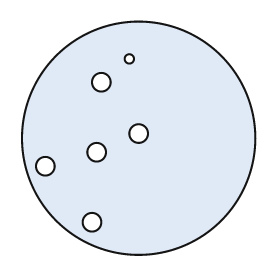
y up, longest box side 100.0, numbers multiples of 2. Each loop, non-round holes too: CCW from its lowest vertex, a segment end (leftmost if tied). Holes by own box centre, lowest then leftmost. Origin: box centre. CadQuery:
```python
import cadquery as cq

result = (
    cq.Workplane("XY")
    .moveTo(0.0, 0.0)
    .circle(50.0)
    .moveTo(-20.0, -36.0)
    .circle(4.0)
    .moveTo(-40.0, -12.0)
    .circle(4.0)
    .moveTo(-18.0, -6.0)
    .circle(4.0)
    .moveTo(0.0, 2.0)
    .circle(4.0)
    .moveTo(-16.0, 24.0)
    .circle(4.0)
    .moveTo(-4.0, 34.0)
    .circle(2.0)
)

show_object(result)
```